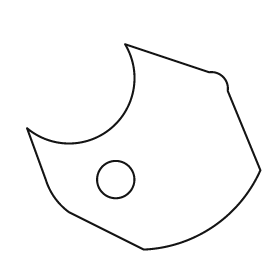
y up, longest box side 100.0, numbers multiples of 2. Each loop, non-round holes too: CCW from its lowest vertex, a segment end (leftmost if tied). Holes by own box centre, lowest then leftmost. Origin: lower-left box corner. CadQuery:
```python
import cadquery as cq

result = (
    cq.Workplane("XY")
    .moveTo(50.0, 0.0)
    .threePointArc((80.0, 10.0), (100.0, 34.0))
    .lineTo(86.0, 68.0)
    .threePointArc((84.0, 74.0), (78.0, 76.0))
    .lineTo(42.0, 88.0)
    .threePointArc((36.0, 52.0), (0.0, 52.0))
    .lineTo(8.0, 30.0)
    .threePointArc((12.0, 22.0), (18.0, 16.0))
    .close()
    .moveTo(38.0, 30.0)
    .circle(8.0)
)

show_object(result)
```